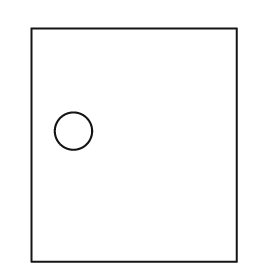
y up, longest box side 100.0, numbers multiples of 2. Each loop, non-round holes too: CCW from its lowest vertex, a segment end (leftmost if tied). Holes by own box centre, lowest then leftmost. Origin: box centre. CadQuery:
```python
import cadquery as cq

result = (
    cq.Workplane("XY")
    .moveTo(-44.0, -50.0)
    .lineTo(44.0, -50.0)
    .lineTo(44.0, 50.0)
    .lineTo(-44.0, 50.0)
    .close()
    .moveTo(-26.0, 6.0)
    .circle(8.0)
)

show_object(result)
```